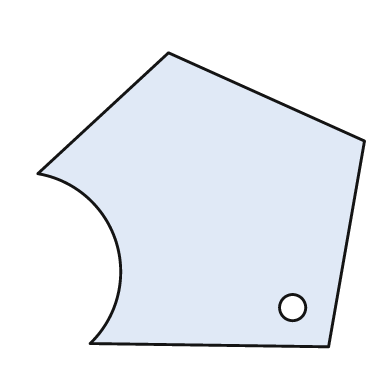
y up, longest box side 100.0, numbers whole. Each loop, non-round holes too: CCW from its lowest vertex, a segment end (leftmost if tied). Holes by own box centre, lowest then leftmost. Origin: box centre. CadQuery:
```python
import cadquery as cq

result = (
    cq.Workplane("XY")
    .moveTo(39.0, -45.0)
    .lineTo(50.0, 18.0)
    .lineTo(-10.0, 45.0)
    .lineTo(-50.0, 8.0)
    .threePointArc((-26.0, -13.0), (-34.0, -44.0))
    .close()
    .moveTo(28.0, -33.0)
    .circle(4.0)
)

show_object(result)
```